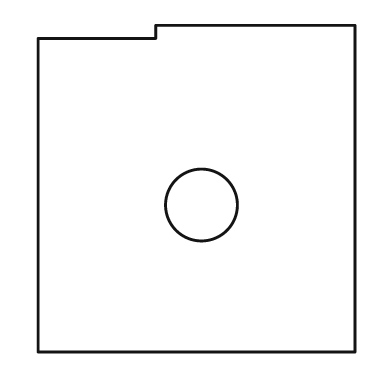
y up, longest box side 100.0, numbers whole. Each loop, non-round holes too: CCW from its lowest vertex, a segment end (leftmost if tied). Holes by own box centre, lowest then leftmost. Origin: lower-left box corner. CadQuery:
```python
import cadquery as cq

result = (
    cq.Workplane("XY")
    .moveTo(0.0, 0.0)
    .lineTo(97.0, 0.0)
    .lineTo(97.0, 100.0)
    .lineTo(36.0, 100.0)
    .lineTo(36.0, 96.0)
    .lineTo(0.0, 96.0)
    .close()
    .moveTo(50.0, 45.0)
    .circle(11.0)
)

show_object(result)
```